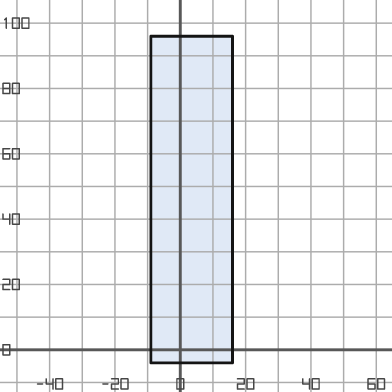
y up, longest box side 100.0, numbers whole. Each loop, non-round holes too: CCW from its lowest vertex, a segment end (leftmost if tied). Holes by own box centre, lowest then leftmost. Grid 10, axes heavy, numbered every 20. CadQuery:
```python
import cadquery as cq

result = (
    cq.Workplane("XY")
    .moveTo(-9.0, -4.0)
    .lineTo(16.0, -4.0)
    .lineTo(16.0, 96.0)
    .lineTo(-9.0, 96.0)
    .close()
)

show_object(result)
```